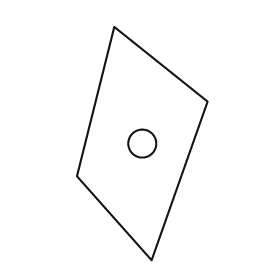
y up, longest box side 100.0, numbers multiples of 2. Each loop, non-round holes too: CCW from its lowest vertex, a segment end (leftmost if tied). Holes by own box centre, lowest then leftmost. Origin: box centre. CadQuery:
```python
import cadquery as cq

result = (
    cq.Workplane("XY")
    .moveTo(4.0, -50.0)
    .lineTo(28.0, 18.0)
    .lineTo(-12.0, 50.0)
    .lineTo(-28.0, -14.0)
    .close()
    .moveTo(0.0, 0.0)
    .circle(6.0)
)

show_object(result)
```